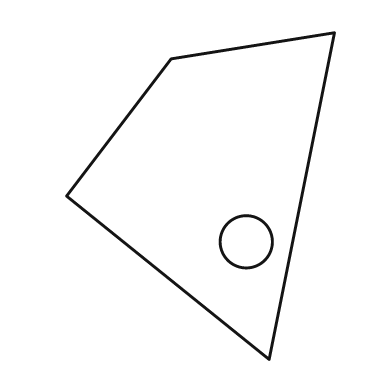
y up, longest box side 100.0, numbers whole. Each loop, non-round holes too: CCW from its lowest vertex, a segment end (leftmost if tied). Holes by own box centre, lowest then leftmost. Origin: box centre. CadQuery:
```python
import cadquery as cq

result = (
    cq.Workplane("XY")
    .moveTo(21.0, -50.0)
    .lineTo(41.0, 50.0)
    .lineTo(-9.0, 42.0)
    .lineTo(-41.0, 0.0)
    .close()
    .moveTo(14.0, -14.0)
    .circle(8.0)
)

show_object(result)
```